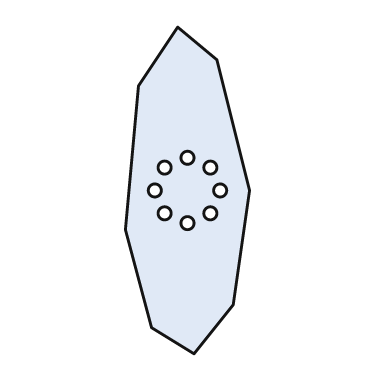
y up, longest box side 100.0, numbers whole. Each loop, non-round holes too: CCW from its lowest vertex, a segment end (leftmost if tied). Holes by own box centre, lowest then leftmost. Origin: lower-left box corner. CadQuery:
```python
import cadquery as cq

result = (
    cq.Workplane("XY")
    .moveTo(21.0, 0.0)
    .lineTo(33.0, 15.0)
    .lineTo(38.0, 50.0)
    .lineTo(28.0, 90.0)
    .lineTo(16.0, 100.0)
    .lineTo(4.0, 82.0)
    .lineTo(0.0, 38.0)
    .lineTo(8.0, 8.0)
    .close()
    .moveTo(19.0, 40.0)
    .circle(2.0)
    .moveTo(12.0, 43.0)
    .circle(2.0)
    .moveTo(26.0, 43.0)
    .circle(2.0)
    .moveTo(9.0, 50.0)
    .circle(2.0)
    .moveTo(29.0, 50.0)
    .circle(2.0)
    .moveTo(12.0, 57.0)
    .circle(2.0)
    .moveTo(26.0, 57.0)
    .circle(2.0)
    .moveTo(19.0, 60.0)
    .circle(2.0)
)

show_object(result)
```